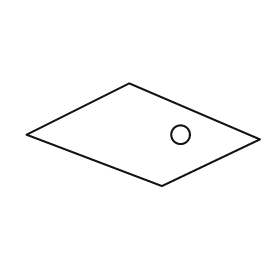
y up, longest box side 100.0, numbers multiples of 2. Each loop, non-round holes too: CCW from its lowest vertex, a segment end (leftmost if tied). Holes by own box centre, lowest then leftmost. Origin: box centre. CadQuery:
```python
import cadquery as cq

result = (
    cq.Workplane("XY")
    .moveTo(8.0, -22.0)
    .lineTo(50.0, -2.0)
    .lineTo(-6.0, 22.0)
    .lineTo(-50.0, 0.0)
    .close()
    .moveTo(16.0, 0.0)
    .circle(4.0)
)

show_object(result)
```